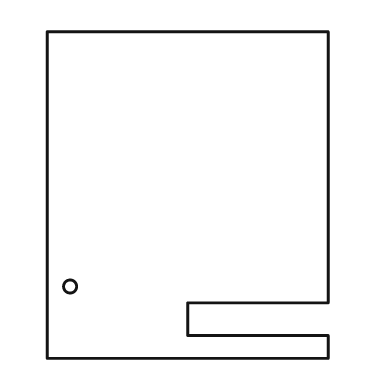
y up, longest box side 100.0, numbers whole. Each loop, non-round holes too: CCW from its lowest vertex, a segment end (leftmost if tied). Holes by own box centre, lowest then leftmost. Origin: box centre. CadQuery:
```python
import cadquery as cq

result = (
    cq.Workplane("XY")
    .moveTo(-43.0, -50.0)
    .lineTo(43.0, -50.0)
    .lineTo(43.0, -43.0)
    .lineTo(0.0, -43.0)
    .lineTo(0.0, -33.0)
    .lineTo(43.0, -33.0)
    .lineTo(43.0, 50.0)
    .lineTo(-43.0, 50.0)
    .close()
    .moveTo(-36.0, -28.0)
    .circle(2.0)
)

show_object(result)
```